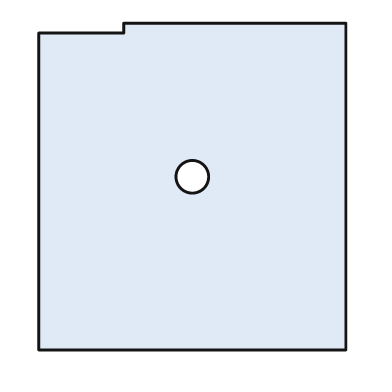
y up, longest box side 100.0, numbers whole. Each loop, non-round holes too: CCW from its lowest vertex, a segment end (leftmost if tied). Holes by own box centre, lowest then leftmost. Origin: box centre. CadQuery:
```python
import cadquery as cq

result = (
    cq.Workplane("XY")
    .moveTo(-47.0, -50.0)
    .lineTo(47.0, -50.0)
    .lineTo(47.0, 50.0)
    .lineTo(-21.0, 50.0)
    .lineTo(-21.0, 47.0)
    .lineTo(-47.0, 47.0)
    .close()
    .moveTo(0.0, 3.0)
    .circle(5.0)
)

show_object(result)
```